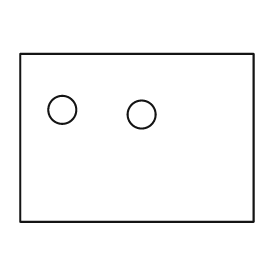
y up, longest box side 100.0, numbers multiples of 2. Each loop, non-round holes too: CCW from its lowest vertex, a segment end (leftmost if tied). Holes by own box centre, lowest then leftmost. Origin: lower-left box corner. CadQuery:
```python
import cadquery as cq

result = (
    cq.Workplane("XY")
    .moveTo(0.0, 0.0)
    .lineTo(100.0, 0.0)
    .lineTo(100.0, 72.0)
    .lineTo(0.0, 72.0)
    .close()
    .moveTo(52.0, 46.0)
    .circle(6.0)
    .moveTo(18.0, 48.0)
    .circle(6.0)
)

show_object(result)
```